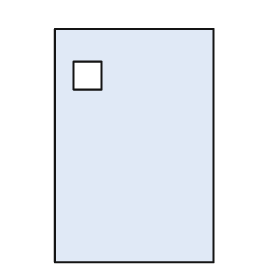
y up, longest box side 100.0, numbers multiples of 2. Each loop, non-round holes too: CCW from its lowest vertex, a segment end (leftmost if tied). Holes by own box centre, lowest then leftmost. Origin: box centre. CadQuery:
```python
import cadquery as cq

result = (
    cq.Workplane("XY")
    .moveTo(-34.0, -50.0)
    .lineTo(34.0, -50.0)
    .lineTo(34.0, 50.0)
    .lineTo(-34.0, 50.0)
    .close()
    .moveTo(-26.0, 24.0)
    .lineTo(-14.0, 24.0)
    .lineTo(-14.0, 36.0)
    .lineTo(-26.0, 36.0)
    .close()
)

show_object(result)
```